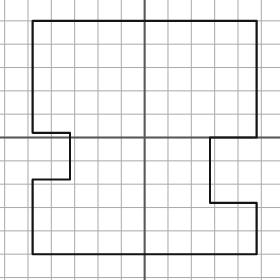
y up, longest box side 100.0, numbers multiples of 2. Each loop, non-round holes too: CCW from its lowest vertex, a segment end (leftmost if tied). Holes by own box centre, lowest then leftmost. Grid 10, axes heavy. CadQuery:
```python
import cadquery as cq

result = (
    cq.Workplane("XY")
    .moveTo(-48.0, -50.0)
    .lineTo(48.0, -50.0)
    .lineTo(48.0, -28.0)
    .lineTo(28.0, -28.0)
    .lineTo(28.0, 0.0)
    .lineTo(48.0, 0.0)
    .lineTo(48.0, 50.0)
    .lineTo(-48.0, 50.0)
    .lineTo(-48.0, 2.0)
    .lineTo(-32.0, 2.0)
    .lineTo(-32.0, -18.0)
    .lineTo(-48.0, -18.0)
    .close()
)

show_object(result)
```